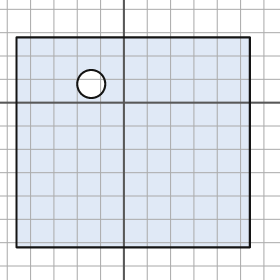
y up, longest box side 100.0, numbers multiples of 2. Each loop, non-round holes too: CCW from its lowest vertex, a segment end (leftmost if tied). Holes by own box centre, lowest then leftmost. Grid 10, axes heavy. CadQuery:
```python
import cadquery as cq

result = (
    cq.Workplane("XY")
    .moveTo(-46.0, -62.0)
    .lineTo(54.0, -62.0)
    .lineTo(54.0, 28.0)
    .lineTo(-46.0, 28.0)
    .close()
    .moveTo(-14.0, 8.0)
    .circle(6.0)
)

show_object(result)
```